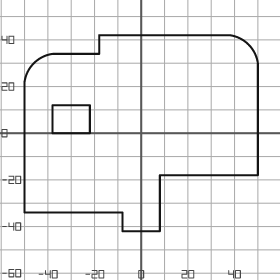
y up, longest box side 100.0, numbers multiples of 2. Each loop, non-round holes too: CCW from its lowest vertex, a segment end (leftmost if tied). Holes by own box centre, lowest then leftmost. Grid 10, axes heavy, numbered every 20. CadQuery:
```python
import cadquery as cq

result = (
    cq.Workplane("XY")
    .moveTo(-8.0, -42.0)
    .lineTo(8.0, -42.0)
    .lineTo(8.0, -18.0)
    .lineTo(50.0, -18.0)
    .lineTo(50.0, 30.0)
    .threePointArc((46.0, 38.0), (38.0, 42.0))
    .lineTo(-18.0, 42.0)
    .lineTo(-18.0, 34.0)
    .lineTo(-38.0, 34.0)
    .threePointArc((-46.0, 30.0), (-50.0, 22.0))
    .lineTo(-50.0, -34.0)
    .lineTo(-8.0, -34.0)
    .close()
    .moveTo(-38.0, 0.0)
    .lineTo(-22.0, 0.0)
    .lineTo(-22.0, 12.0)
    .lineTo(-38.0, 12.0)
    .close()
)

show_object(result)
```